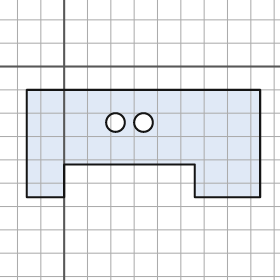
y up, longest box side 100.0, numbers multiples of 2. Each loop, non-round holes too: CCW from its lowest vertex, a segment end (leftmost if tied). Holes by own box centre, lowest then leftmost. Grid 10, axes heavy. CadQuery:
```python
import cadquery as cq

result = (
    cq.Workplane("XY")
    .moveTo(-16.0, -56.0)
    .lineTo(0.0, -56.0)
    .lineTo(0.0, -42.0)
    .lineTo(56.0, -42.0)
    .lineTo(56.0, -56.0)
    .lineTo(84.0, -56.0)
    .lineTo(84.0, -10.0)
    .lineTo(-16.0, -10.0)
    .close()
    .moveTo(22.0, -24.0)
    .circle(4.0)
    .moveTo(34.0, -24.0)
    .circle(4.0)
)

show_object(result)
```